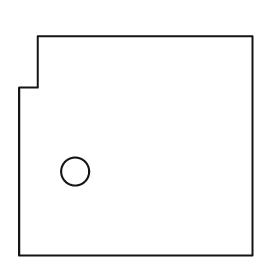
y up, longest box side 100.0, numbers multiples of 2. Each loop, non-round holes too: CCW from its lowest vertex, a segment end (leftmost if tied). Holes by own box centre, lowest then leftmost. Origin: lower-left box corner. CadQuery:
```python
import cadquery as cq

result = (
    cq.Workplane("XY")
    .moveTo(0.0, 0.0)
    .lineTo(100.0, 0.0)
    .lineTo(100.0, 94.0)
    .lineTo(8.0, 94.0)
    .lineTo(8.0, 72.0)
    .lineTo(0.0, 72.0)
    .close()
    .moveTo(24.0, 36.0)
    .circle(6.0)
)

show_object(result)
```